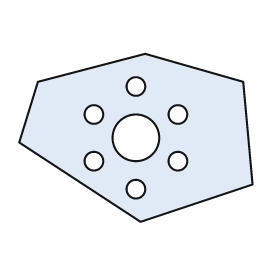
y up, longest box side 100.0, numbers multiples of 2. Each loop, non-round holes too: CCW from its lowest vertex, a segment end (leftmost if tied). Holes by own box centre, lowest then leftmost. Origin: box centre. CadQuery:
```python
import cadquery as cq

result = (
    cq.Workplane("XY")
    .moveTo(2.0, -36.0)
    .lineTo(50.0, -20.0)
    .lineTo(46.0, 24.0)
    .lineTo(4.0, 36.0)
    .lineTo(-42.0, 24.0)
    .lineTo(-50.0, -2.0)
    .close()
    .moveTo(0.0, -22.0)
    .circle(4.0)
    .moveTo(-18.0, -10.0)
    .circle(4.0)
    .moveTo(18.0, -10.0)
    .circle(4.0)
    .moveTo(0.0, 0.0)
    .circle(10.0)
    .moveTo(-18.0, 10.0)
    .circle(4.0)
    .moveTo(18.0, 10.0)
    .circle(4.0)
    .moveTo(0.0, 22.0)
    .circle(4.0)
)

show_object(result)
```